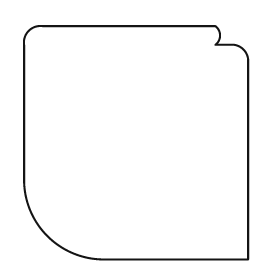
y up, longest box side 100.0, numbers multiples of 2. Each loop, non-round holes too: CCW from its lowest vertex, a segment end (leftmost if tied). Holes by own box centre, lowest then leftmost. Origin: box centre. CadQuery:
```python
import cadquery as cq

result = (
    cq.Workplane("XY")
    .moveTo(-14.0, -50.0)
    .lineTo(48.0, -50.0)
    .lineTo(48.0, 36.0)
    .threePointArc((46.0, 40.0), (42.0, 42.0))
    .lineTo(34.0, 42.0)
    .threePointArc((36.0, 46.0), (34.0, 50.0))
    .lineTo(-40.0, 50.0)
    .threePointArc((-46.0, 48.0), (-48.0, 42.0))
    .lineTo(-48.0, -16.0)
    .threePointArc((-38.0, -40.0), (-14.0, -50.0))
    .close()
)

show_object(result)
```